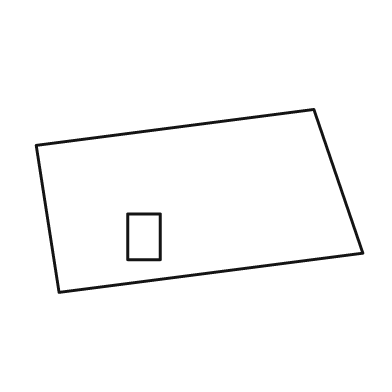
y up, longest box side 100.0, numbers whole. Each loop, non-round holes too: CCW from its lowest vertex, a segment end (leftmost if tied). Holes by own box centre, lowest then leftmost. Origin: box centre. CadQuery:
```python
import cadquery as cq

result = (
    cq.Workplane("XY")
    .moveTo(-43.0, -28.0)
    .lineTo(50.0, -16.0)
    .lineTo(35.0, 28.0)
    .lineTo(-50.0, 17.0)
    .close()
    .moveTo(-22.0, -18.0)
    .lineTo(-12.0, -18.0)
    .lineTo(-12.0, -4.0)
    .lineTo(-22.0, -4.0)
    .close()
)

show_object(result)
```